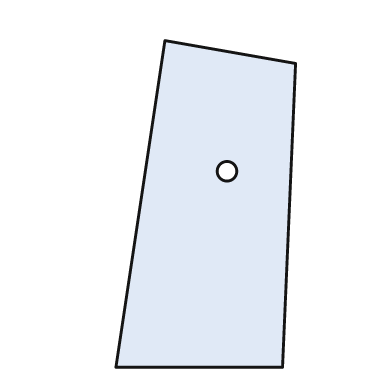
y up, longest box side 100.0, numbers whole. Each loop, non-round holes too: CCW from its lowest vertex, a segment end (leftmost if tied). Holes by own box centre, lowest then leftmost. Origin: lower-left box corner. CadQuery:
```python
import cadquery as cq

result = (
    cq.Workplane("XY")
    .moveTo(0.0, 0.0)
    .lineTo(51.0, 0.0)
    .lineTo(55.0, 93.0)
    .lineTo(15.0, 100.0)
    .close()
    .moveTo(34.0, 60.0)
    .circle(3.0)
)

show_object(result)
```